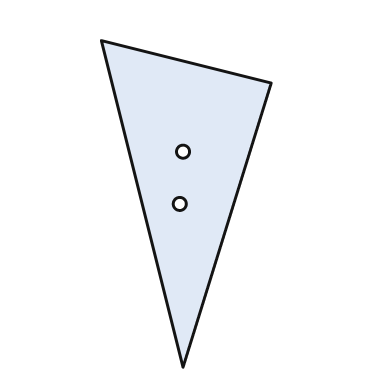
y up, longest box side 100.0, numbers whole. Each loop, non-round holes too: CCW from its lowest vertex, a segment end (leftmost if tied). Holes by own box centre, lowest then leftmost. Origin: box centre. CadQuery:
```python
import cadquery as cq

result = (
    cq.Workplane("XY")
    .moveTo(-1.0, -50.0)
    .lineTo(26.0, 37.0)
    .lineTo(-26.0, 50.0)
    .close()
    .moveTo(-2.0, 0.0)
    .circle(2.0)
    .moveTo(-1.0, 16.0)
    .circle(2.0)
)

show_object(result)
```